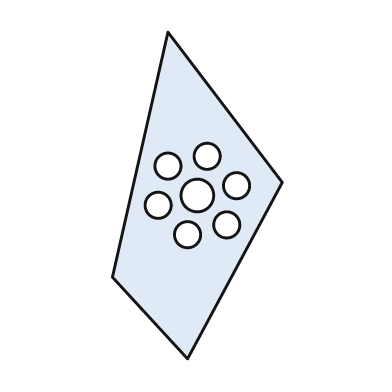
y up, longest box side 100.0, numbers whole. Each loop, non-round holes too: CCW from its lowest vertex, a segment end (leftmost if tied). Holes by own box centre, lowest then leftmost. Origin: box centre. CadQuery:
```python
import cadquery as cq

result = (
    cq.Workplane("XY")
    .moveTo(-3.0, -50.0)
    .lineTo(26.0, 4.0)
    .lineTo(-9.0, 50.0)
    .lineTo(-26.0, -25.0)
    .close()
    .moveTo(-3.0, -12.0)
    .circle(4.0)
    .moveTo(9.0, -9.0)
    .circle(4.0)
    .moveTo(-12.0, -3.0)
    .circle(4.0)
    .moveTo(0.0, 0.0)
    .circle(5.0)
    .moveTo(12.0, 3.0)
    .circle(4.0)
    .moveTo(-9.0, 9.0)
    .circle(4.0)
    .moveTo(3.0, 12.0)
    .circle(4.0)
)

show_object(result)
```